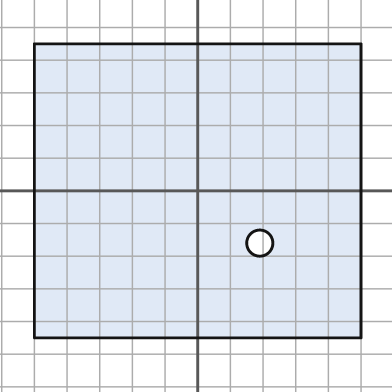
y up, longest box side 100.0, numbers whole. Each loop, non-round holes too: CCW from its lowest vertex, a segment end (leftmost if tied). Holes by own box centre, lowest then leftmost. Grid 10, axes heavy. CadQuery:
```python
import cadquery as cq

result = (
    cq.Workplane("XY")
    .moveTo(-50.0, -45.0)
    .lineTo(50.0, -45.0)
    .lineTo(50.0, 45.0)
    .lineTo(-50.0, 45.0)
    .close()
    .moveTo(19.0, -16.0)
    .circle(4.0)
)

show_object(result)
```